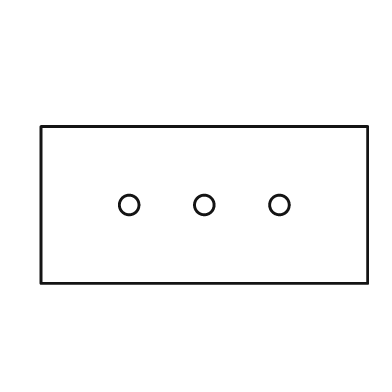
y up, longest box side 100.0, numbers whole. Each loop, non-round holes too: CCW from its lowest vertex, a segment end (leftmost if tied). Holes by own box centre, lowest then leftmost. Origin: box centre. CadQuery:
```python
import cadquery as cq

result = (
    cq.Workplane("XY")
    .moveTo(-50.0, -24.0)
    .lineTo(50.0, -24.0)
    .lineTo(50.0, 24.0)
    .lineTo(-50.0, 24.0)
    .close()
    .moveTo(-23.0, 0.0)
    .circle(3.0)
    .moveTo(0.0, 0.0)
    .circle(3.0)
    .moveTo(23.0, 0.0)
    .circle(3.0)
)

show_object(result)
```